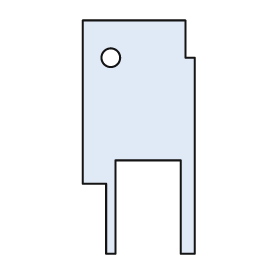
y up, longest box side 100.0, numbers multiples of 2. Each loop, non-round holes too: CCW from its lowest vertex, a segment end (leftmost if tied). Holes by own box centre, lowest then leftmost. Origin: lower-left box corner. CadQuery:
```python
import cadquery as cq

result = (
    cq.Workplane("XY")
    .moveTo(10.0, 0.0)
    .lineTo(14.0, 0.0)
    .lineTo(14.0, 40.0)
    .lineTo(42.0, 40.0)
    .lineTo(42.0, 0.0)
    .lineTo(48.0, 0.0)
    .lineTo(48.0, 84.0)
    .lineTo(44.0, 84.0)
    .lineTo(44.0, 100.0)
    .lineTo(0.0, 100.0)
    .lineTo(0.0, 30.0)
    .lineTo(10.0, 30.0)
    .close()
    .moveTo(12.0, 84.0)
    .circle(4.0)
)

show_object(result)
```